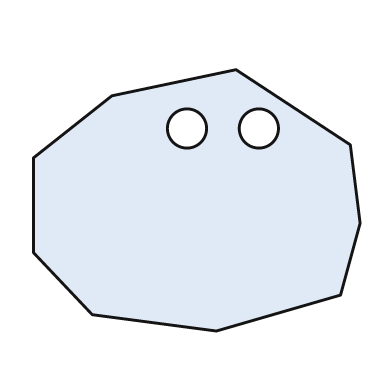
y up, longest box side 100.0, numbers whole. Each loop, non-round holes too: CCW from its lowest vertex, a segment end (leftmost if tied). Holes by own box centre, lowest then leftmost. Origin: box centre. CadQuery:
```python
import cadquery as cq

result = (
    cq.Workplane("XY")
    .moveTo(6.0, -40.0)
    .lineTo(44.0, -29.0)
    .lineTo(50.0, -7.0)
    .lineTo(47.0, 17.0)
    .lineTo(12.0, 40.0)
    .lineTo(-26.0, 32.0)
    .lineTo(-50.0, 13.0)
    .lineTo(-50.0, -16.0)
    .lineTo(-32.0, -35.0)
    .close()
    .moveTo(-3.0, 22.0)
    .circle(6.0)
    .moveTo(19.0, 22.0)
    .circle(6.0)
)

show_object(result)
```